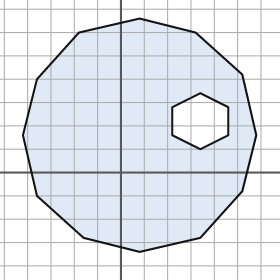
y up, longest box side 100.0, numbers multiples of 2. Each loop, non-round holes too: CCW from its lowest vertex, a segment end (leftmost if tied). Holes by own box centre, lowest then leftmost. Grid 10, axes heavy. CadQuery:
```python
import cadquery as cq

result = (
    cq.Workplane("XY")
    .moveTo(8.0, -34.0)
    .lineTo(34.0, -28.0)
    .lineTo(52.0, -8.0)
    .lineTo(58.0, 16.0)
    .lineTo(52.0, 42.0)
    .lineTo(32.0, 60.0)
    .lineTo(8.0, 66.0)
    .lineTo(-18.0, 60.0)
    .lineTo(-36.0, 40.0)
    .lineTo(-42.0, 16.0)
    .lineTo(-36.0, -10.0)
    .lineTo(-16.0, -28.0)
    .close()
    .moveTo(34.0, 10.0)
    .lineTo(46.0, 16.0)
    .lineTo(46.0, 28.0)
    .lineTo(34.0, 34.0)
    .lineTo(22.0, 28.0)
    .lineTo(22.0, 16.0)
    .close()
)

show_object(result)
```